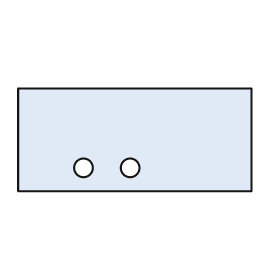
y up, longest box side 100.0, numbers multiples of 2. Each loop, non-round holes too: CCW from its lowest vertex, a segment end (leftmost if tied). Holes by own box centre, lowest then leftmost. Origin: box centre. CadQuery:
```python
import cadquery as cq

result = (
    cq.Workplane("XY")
    .moveTo(-50.0, -22.0)
    .lineTo(50.0, -22.0)
    .lineTo(50.0, 22.0)
    .lineTo(-50.0, 22.0)
    .close()
    .moveTo(-22.0, -12.0)
    .circle(4.0)
    .moveTo(-2.0, -12.0)
    .circle(4.0)
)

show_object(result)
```